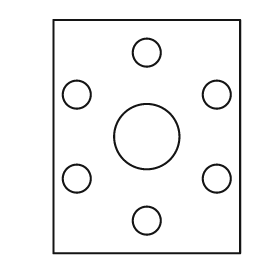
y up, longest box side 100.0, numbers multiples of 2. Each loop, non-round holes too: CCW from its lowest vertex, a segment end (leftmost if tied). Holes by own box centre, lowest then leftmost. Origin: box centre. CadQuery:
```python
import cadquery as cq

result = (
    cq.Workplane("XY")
    .moveTo(-40.0, -50.0)
    .lineTo(40.0, -50.0)
    .lineTo(40.0, 50.0)
    .lineTo(-40.0, 50.0)
    .close()
    .moveTo(0.0, -36.0)
    .circle(6.0)
    .moveTo(-30.0, -18.0)
    .circle(6.0)
    .moveTo(30.0, -18.0)
    .circle(6.0)
    .moveTo(0.0, 0.0)
    .circle(14.0)
    .moveTo(-30.0, 18.0)
    .circle(6.0)
    .moveTo(30.0, 18.0)
    .circle(6.0)
    .moveTo(0.0, 36.0)
    .circle(6.0)
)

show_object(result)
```